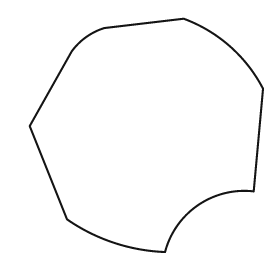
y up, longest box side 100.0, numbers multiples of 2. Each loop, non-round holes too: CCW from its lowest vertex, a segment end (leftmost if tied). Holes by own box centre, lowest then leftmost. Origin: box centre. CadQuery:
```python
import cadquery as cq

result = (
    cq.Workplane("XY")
    .moveTo(8.0, -50.0)
    .threePointArc((22.0, -30.0), (46.0, -24.0))
    .lineTo(50.0, 20.0)
    .threePointArc((36.0, 38.0), (16.0, 50.0))
    .lineTo(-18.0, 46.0)
    .threePointArc((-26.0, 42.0), (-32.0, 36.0))
    .lineTo(-50.0, 4.0)
    .lineTo(-34.0, -36.0)
    .threePointArc((-14.0, -46.0), (8.0, -50.0))
    .close()
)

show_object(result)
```